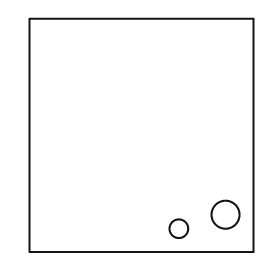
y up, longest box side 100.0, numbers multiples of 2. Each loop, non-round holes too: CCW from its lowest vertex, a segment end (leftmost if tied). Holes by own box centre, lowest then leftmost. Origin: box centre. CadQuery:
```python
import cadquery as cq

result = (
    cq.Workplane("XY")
    .moveTo(-48.0, -50.0)
    .lineTo(48.0, -50.0)
    .lineTo(48.0, 50.0)
    .lineTo(-48.0, 50.0)
    .close()
    .moveTo(16.0, -40.0)
    .circle(4.0)
    .moveTo(36.0, -34.0)
    .circle(6.0)
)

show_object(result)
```